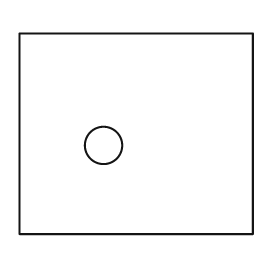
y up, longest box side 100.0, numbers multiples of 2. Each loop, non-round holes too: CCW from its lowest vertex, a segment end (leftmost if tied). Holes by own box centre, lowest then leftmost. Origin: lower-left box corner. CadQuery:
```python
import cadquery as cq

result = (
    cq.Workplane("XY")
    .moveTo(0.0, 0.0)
    .lineTo(100.0, 0.0)
    .lineTo(100.0, 86.0)
    .lineTo(0.0, 86.0)
    .close()
    .moveTo(36.0, 38.0)
    .circle(8.0)
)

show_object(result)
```